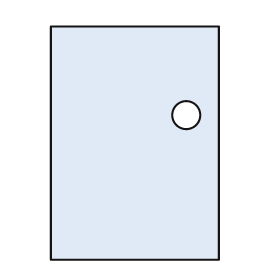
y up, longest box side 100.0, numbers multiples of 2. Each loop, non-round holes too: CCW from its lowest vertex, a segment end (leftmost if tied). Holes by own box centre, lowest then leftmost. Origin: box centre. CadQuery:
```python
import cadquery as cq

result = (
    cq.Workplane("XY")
    .moveTo(-36.0, -50.0)
    .lineTo(36.0, -50.0)
    .lineTo(36.0, 50.0)
    .lineTo(-36.0, 50.0)
    .close()
    .moveTo(22.0, 12.0)
    .circle(6.0)
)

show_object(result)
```